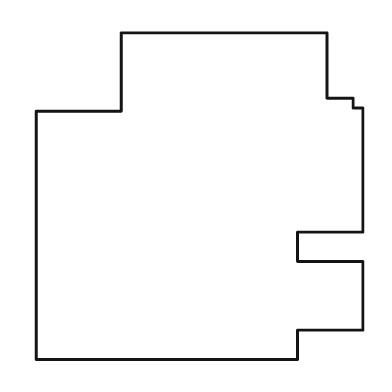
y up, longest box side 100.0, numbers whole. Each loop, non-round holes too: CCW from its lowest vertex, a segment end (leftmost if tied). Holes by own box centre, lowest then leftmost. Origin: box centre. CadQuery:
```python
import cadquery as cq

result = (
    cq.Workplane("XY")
    .moveTo(-50.0, -50.0)
    .lineTo(30.0, -50.0)
    .lineTo(30.0, -41.0)
    .lineTo(50.0, -41.0)
    .lineTo(50.0, -20.0)
    .lineTo(30.0, -20.0)
    .lineTo(30.0, -11.0)
    .lineTo(50.0, -11.0)
    .lineTo(50.0, 27.0)
    .lineTo(47.0, 27.0)
    .lineTo(47.0, 30.0)
    .lineTo(39.0, 30.0)
    .lineTo(39.0, 50.0)
    .lineTo(-24.0, 50.0)
    .lineTo(-24.0, 26.0)
    .lineTo(-50.0, 26.0)
    .close()
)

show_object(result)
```